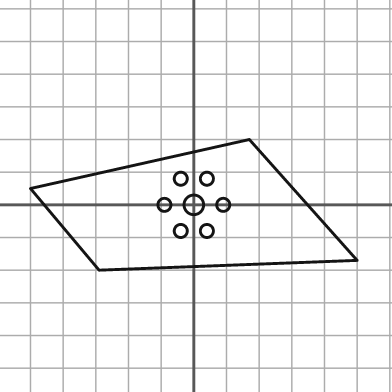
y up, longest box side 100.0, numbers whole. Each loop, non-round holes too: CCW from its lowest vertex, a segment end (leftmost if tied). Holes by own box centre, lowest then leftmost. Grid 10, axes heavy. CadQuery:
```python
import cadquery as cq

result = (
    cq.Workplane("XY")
    .moveTo(-29.0, -20.0)
    .lineTo(50.0, -17.0)
    .lineTo(17.0, 20.0)
    .lineTo(-50.0, 5.0)
    .close()
    .moveTo(-4.0, -8.0)
    .circle(2.0)
    .moveTo(4.0, -8.0)
    .circle(2.0)
    .moveTo(-9.0, 0.0)
    .circle(2.0)
    .moveTo(0.0, 0.0)
    .circle(3.0)
    .moveTo(9.0, 0.0)
    .circle(2.0)
    .moveTo(-4.0, 8.0)
    .circle(2.0)
    .moveTo(4.0, 8.0)
    .circle(2.0)
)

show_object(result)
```